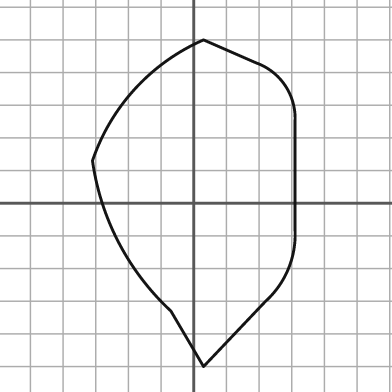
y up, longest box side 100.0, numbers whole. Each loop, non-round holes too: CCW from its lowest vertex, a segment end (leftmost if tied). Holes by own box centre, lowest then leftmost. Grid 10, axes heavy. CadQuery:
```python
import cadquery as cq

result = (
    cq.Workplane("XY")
    .moveTo(3.0, -50.0)
    .lineTo(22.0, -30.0)
    .threePointArc((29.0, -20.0), (31.0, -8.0))
    .lineTo(31.0, 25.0)
    .threePointArc((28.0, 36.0), (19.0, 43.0))
    .lineTo(3.0, 50.0)
    .threePointArc((-18.0, 35.0), (-31.0, 13.0))
    .threePointArc((-23.0, -12.0), (-7.0, -33.0))
    .close()
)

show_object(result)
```